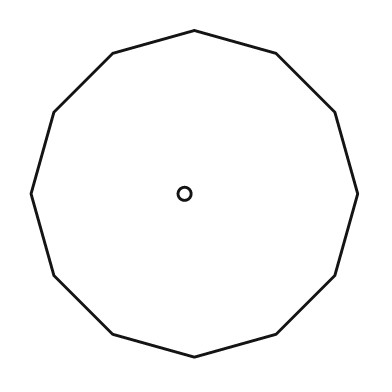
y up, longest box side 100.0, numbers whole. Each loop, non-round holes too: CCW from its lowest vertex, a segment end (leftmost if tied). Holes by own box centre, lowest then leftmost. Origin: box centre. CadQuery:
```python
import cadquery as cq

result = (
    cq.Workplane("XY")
    .moveTo(0.0, -50.0)
    .lineTo(25.0, -43.0)
    .lineTo(43.0, -25.0)
    .lineTo(50.0, 0.0)
    .lineTo(43.0, 25.0)
    .lineTo(25.0, 43.0)
    .lineTo(0.0, 50.0)
    .lineTo(-25.0, 43.0)
    .lineTo(-43.0, 25.0)
    .lineTo(-50.0, 0.0)
    .lineTo(-43.0, -25.0)
    .lineTo(-25.0, -43.0)
    .close()
    .moveTo(-3.0, 0.0)
    .circle(2.0)
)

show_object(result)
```